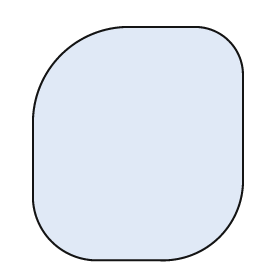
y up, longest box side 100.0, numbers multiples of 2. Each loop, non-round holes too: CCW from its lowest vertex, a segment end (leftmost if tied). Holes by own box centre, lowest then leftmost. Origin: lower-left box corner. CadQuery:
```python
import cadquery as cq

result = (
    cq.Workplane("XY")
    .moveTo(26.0, 0.0)
    .lineTo(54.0, 0.0)
    .threePointArc((80.0, 10.0), (90.0, 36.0))
    .lineTo(90.0, 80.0)
    .threePointArc((84.0, 94.0), (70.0, 100.0))
    .lineTo(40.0, 100.0)
    .threePointArc((12.0, 88.0), (0.0, 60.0))
    .lineTo(0.0, 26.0)
    .threePointArc((8.0, 8.0), (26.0, 0.0))
    .close()
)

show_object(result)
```